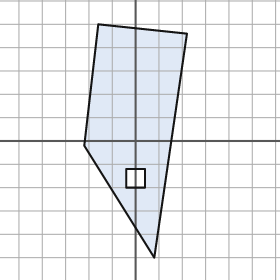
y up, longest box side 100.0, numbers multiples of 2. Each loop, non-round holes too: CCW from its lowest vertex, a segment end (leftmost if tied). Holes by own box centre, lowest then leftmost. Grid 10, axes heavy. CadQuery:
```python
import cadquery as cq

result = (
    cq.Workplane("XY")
    .moveTo(8.0, -50.0)
    .lineTo(22.0, 46.0)
    .lineTo(-16.0, 50.0)
    .lineTo(-22.0, -2.0)
    .close()
    .moveTo(-4.0, -20.0)
    .lineTo(4.0, -20.0)
    .lineTo(4.0, -12.0)
    .lineTo(-4.0, -12.0)
    .close()
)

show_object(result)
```